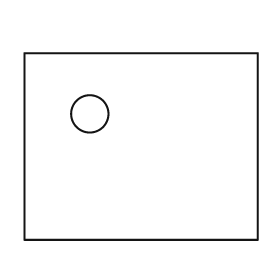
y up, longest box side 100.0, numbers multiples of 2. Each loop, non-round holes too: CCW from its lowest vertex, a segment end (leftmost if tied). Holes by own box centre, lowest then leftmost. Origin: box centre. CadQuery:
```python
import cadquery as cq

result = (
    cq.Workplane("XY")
    .moveTo(-50.0, -40.0)
    .lineTo(50.0, -40.0)
    .lineTo(50.0, 40.0)
    .lineTo(-50.0, 40.0)
    .close()
    .moveTo(-22.0, 14.0)
    .circle(8.0)
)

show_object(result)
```